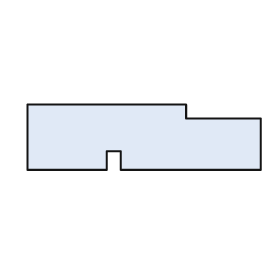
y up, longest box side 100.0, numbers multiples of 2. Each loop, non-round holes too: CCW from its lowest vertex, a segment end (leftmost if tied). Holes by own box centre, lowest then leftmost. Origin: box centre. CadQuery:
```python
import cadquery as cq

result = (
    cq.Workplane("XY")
    .moveTo(-50.0, -14.0)
    .lineTo(-16.0, -14.0)
    .lineTo(-16.0, -6.0)
    .lineTo(-10.0, -6.0)
    .lineTo(-10.0, -14.0)
    .lineTo(50.0, -14.0)
    .lineTo(50.0, 8.0)
    .lineTo(18.0, 8.0)
    .lineTo(18.0, 14.0)
    .lineTo(-50.0, 14.0)
    .close()
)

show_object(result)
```